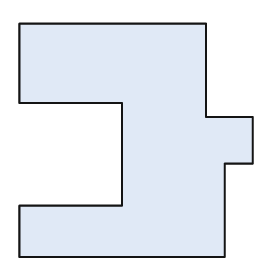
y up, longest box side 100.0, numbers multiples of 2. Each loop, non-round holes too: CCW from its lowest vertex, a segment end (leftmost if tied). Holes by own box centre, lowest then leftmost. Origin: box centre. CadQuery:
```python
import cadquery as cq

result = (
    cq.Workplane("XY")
    .moveTo(-50.0, -50.0)
    .lineTo(38.0, -50.0)
    .lineTo(38.0, -10.0)
    .lineTo(50.0, -10.0)
    .lineTo(50.0, 10.0)
    .lineTo(30.0, 10.0)
    .lineTo(30.0, 50.0)
    .lineTo(-50.0, 50.0)
    .lineTo(-50.0, 16.0)
    .lineTo(-6.0, 16.0)
    .lineTo(-6.0, -28.0)
    .lineTo(-50.0, -28.0)
    .close()
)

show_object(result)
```